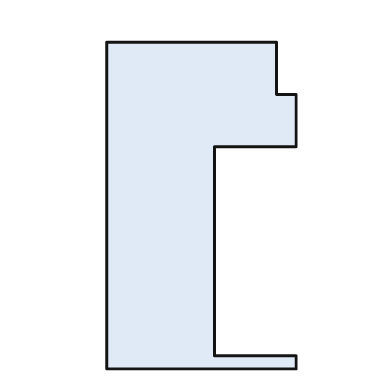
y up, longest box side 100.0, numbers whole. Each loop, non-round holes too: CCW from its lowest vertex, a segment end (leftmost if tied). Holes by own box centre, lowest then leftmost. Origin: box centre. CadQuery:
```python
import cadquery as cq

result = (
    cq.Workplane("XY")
    .moveTo(-29.0, -50.0)
    .lineTo(29.0, -50.0)
    .lineTo(29.0, -46.0)
    .lineTo(4.0, -46.0)
    .lineTo(4.0, 18.0)
    .lineTo(29.0, 18.0)
    .lineTo(29.0, 34.0)
    .lineTo(23.0, 34.0)
    .lineTo(23.0, 50.0)
    .lineTo(-29.0, 50.0)
    .close()
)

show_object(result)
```